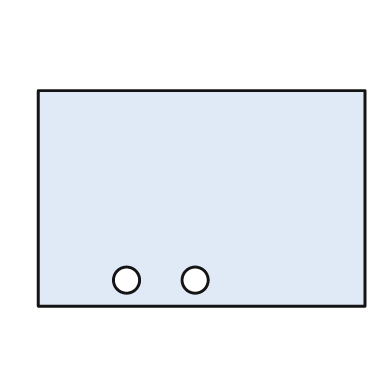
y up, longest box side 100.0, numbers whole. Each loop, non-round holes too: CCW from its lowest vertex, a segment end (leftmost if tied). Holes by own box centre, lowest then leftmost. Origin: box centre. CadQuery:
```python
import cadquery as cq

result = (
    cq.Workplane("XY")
    .moveTo(-50.0, -33.0)
    .lineTo(50.0, -33.0)
    .lineTo(50.0, 33.0)
    .lineTo(-50.0, 33.0)
    .close()
    .moveTo(-23.0, -25.0)
    .circle(4.0)
    .moveTo(-2.0, -25.0)
    .circle(4.0)
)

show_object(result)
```